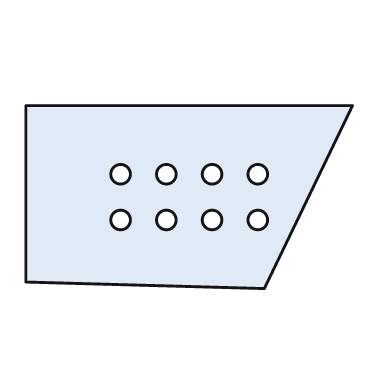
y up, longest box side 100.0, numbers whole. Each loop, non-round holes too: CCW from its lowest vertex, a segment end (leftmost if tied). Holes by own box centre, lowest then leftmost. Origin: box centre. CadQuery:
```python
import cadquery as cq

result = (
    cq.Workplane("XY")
    .moveTo(23.0, -28.0)
    .lineTo(50.0, 28.0)
    .lineTo(-50.0, 28.0)
    .lineTo(-50.0, -26.0)
    .close()
    .moveTo(-21.0, -7.0)
    .circle(3.0)
    .moveTo(-7.0, -7.0)
    .circle(3.0)
    .moveTo(7.0, -7.0)
    .circle(3.0)
    .moveTo(21.0, -7.0)
    .circle(3.0)
    .moveTo(-21.0, 7.0)
    .circle(3.0)
    .moveTo(-7.0, 7.0)
    .circle(3.0)
    .moveTo(7.0, 7.0)
    .circle(3.0)
    .moveTo(21.0, 7.0)
    .circle(3.0)
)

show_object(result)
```